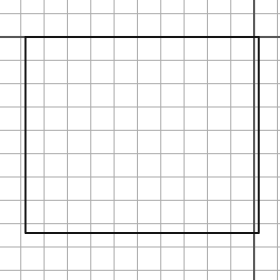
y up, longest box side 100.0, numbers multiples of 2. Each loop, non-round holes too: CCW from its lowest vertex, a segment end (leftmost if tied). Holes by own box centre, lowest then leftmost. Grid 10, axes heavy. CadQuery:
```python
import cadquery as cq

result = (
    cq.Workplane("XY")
    .moveTo(-98.0, -84.0)
    .lineTo(2.0, -84.0)
    .lineTo(2.0, 0.0)
    .lineTo(-98.0, 0.0)
    .close()
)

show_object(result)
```